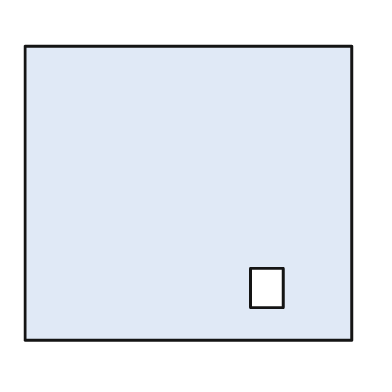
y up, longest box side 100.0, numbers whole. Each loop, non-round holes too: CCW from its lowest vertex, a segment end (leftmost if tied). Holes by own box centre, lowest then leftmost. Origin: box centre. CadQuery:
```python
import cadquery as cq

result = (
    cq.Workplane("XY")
    .moveTo(-50.0, -45.0)
    .lineTo(50.0, -45.0)
    .lineTo(50.0, 45.0)
    .lineTo(-50.0, 45.0)
    .close()
    .moveTo(19.0, -35.0)
    .lineTo(29.0, -35.0)
    .lineTo(29.0, -23.0)
    .lineTo(19.0, -23.0)
    .close()
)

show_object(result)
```